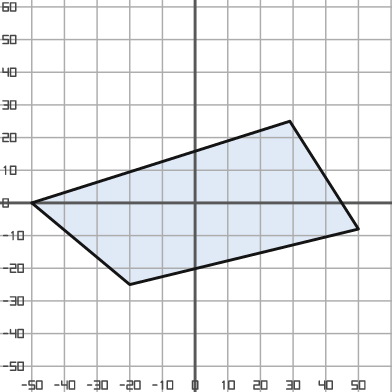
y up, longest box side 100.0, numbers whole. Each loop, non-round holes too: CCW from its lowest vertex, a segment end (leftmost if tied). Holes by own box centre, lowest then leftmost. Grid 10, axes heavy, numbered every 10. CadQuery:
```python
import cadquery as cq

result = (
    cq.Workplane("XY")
    .moveTo(-20.0, -25.0)
    .lineTo(50.0, -8.0)
    .lineTo(29.0, 25.0)
    .lineTo(-50.0, 0.0)
    .close()
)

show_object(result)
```